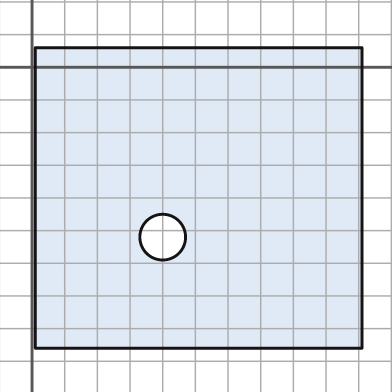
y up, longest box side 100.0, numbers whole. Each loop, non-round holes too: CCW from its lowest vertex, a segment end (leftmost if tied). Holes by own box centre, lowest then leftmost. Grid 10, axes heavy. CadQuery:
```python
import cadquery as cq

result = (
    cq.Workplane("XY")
    .moveTo(1.0, -86.0)
    .lineTo(101.0, -86.0)
    .lineTo(101.0, 6.0)
    .lineTo(1.0, 6.0)
    .close()
    .moveTo(40.0, -52.0)
    .circle(7.0)
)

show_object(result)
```